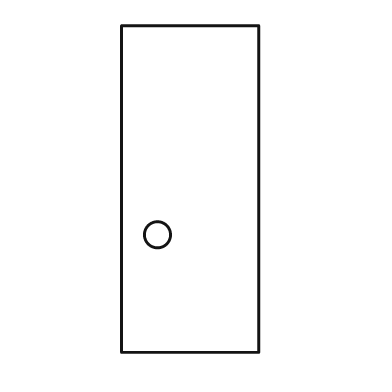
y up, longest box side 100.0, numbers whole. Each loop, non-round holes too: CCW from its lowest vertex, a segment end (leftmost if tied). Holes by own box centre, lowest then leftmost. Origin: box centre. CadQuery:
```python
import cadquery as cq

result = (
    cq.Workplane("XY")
    .moveTo(-21.0, -50.0)
    .lineTo(21.0, -50.0)
    .lineTo(21.0, 50.0)
    .lineTo(-21.0, 50.0)
    .close()
    .moveTo(-10.0, -14.0)
    .circle(4.0)
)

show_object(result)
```